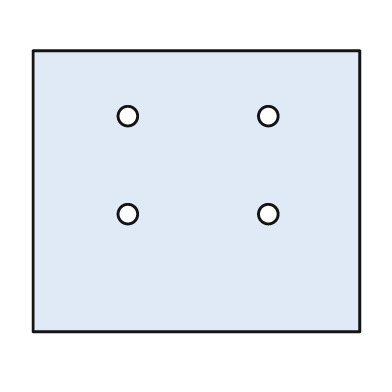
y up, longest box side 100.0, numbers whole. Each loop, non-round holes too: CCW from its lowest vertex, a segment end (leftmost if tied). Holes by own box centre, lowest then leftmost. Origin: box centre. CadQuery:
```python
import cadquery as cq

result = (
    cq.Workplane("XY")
    .moveTo(-50.0, -43.0)
    .lineTo(50.0, -43.0)
    .lineTo(50.0, 43.0)
    .lineTo(-50.0, 43.0)
    .close()
    .moveTo(-21.0, -7.0)
    .circle(3.0)
    .moveTo(22.0, -7.0)
    .circle(3.0)
    .moveTo(-21.0, 23.0)
    .circle(3.0)
    .moveTo(22.0, 23.0)
    .circle(3.0)
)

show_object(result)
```